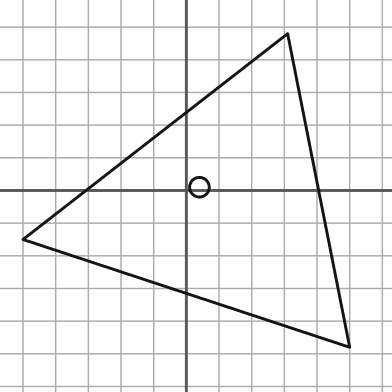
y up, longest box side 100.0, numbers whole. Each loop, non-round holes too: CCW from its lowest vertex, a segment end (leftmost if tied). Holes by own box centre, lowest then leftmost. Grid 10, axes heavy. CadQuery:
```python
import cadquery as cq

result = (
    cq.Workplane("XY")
    .moveTo(50.0, -48.0)
    .lineTo(31.0, 48.0)
    .lineTo(-50.0, -15.0)
    .close()
    .moveTo(4.0, 1.0)
    .circle(3.0)
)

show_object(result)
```